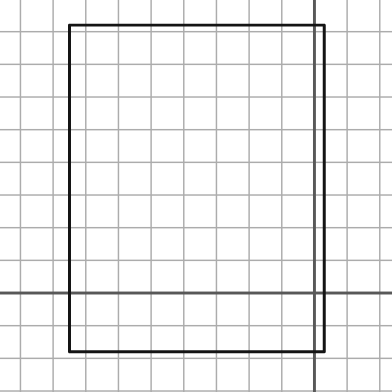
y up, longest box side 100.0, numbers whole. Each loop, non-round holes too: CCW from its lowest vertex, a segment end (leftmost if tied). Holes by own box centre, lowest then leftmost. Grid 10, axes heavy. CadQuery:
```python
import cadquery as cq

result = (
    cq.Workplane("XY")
    .moveTo(-75.0, -18.0)
    .lineTo(3.0, -18.0)
    .lineTo(3.0, 82.0)
    .lineTo(-75.0, 82.0)
    .close()
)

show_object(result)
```